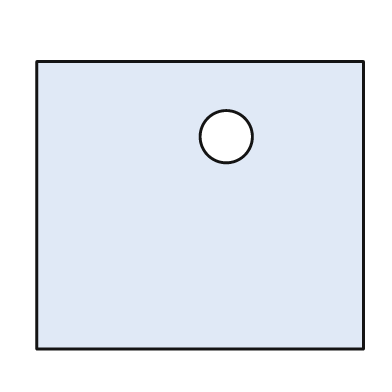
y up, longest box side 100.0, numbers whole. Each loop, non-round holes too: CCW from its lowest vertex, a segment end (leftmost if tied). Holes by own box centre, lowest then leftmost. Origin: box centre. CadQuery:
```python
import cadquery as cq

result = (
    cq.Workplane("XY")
    .moveTo(-50.0, -44.0)
    .lineTo(50.0, -44.0)
    .lineTo(50.0, 44.0)
    .lineTo(-50.0, 44.0)
    .close()
    .moveTo(8.0, 21.0)
    .circle(8.0)
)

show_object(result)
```